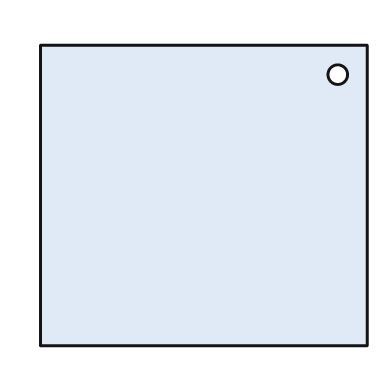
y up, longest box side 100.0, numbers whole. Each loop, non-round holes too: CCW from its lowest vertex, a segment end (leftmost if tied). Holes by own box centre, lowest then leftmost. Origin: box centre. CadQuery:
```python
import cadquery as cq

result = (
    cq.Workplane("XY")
    .moveTo(-50.0, -46.0)
    .lineTo(50.0, -46.0)
    .lineTo(50.0, 46.0)
    .lineTo(-50.0, 46.0)
    .close()
    .moveTo(41.0, 37.0)
    .circle(3.0)
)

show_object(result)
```